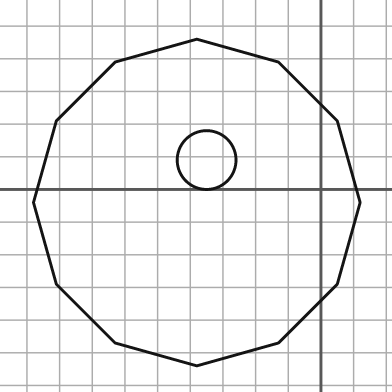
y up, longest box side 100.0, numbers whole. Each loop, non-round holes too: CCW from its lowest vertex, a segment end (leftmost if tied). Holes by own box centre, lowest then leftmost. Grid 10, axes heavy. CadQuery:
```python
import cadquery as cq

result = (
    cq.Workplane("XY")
    .moveTo(-38.0, -54.0)
    .lineTo(-13.0, -47.0)
    .lineTo(5.0, -29.0)
    .lineTo(12.0, -4.0)
    .lineTo(5.0, 21.0)
    .lineTo(-13.0, 39.0)
    .lineTo(-38.0, 46.0)
    .lineTo(-63.0, 39.0)
    .lineTo(-81.0, 21.0)
    .lineTo(-88.0, -4.0)
    .lineTo(-81.0, -29.0)
    .lineTo(-63.0, -47.0)
    .close()
    .moveTo(-35.0, 9.0)
    .circle(9.0)
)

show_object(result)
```